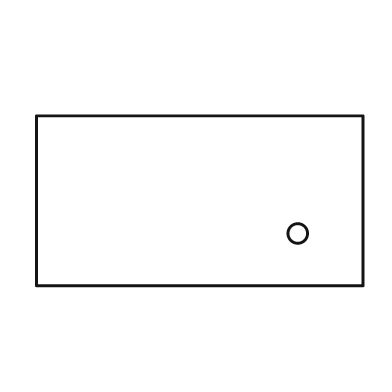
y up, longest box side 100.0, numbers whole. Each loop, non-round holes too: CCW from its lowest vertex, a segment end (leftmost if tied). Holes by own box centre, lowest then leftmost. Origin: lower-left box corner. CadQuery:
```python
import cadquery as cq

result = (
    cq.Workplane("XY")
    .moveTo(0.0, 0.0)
    .lineTo(100.0, 0.0)
    .lineTo(100.0, 52.0)
    .lineTo(0.0, 52.0)
    .close()
    .moveTo(80.0, 16.0)
    .circle(3.0)
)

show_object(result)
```